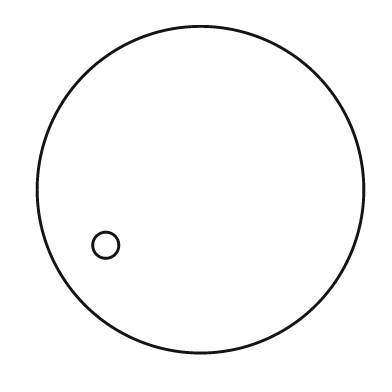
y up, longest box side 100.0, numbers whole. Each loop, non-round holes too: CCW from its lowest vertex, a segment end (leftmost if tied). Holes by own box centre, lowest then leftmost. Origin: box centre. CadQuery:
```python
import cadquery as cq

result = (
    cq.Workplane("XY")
    .moveTo(0.0, 0.0)
    .circle(50.0)
    .moveTo(-29.0, -17.0)
    .circle(4.0)
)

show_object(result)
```